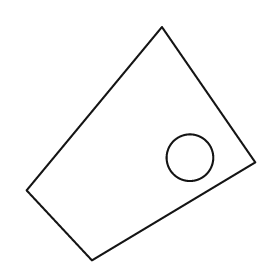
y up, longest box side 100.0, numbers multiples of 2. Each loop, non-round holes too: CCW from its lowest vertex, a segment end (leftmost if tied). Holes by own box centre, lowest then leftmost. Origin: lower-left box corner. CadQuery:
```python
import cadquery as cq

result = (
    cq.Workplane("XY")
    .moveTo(28.0, 0.0)
    .lineTo(98.0, 42.0)
    .lineTo(58.0, 100.0)
    .lineTo(0.0, 30.0)
    .close()
    .moveTo(70.0, 44.0)
    .circle(10.0)
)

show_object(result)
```